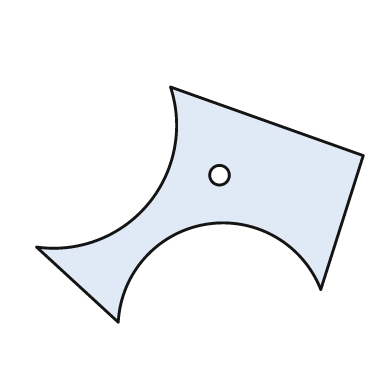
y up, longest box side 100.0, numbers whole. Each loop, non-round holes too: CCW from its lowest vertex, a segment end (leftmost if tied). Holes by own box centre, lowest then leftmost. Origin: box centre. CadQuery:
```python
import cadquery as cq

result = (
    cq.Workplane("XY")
    .moveTo(-25.0, -36.0)
    .threePointArc((2.0, -6.0), (37.0, -26.0))
    .lineTo(50.0, 15.0)
    .lineTo(-9.0, 36.0)
    .threePointArc((-16.0, 0.0), (-50.0, -13.0))
    .close()
    .moveTo(6.0, 9.0)
    .circle(3.0)
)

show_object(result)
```